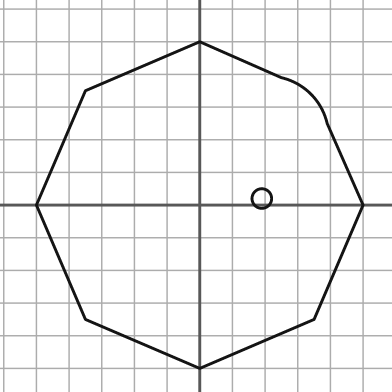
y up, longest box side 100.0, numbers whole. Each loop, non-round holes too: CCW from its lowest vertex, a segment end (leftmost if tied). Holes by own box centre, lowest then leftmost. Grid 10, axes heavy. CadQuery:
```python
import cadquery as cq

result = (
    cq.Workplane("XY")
    .moveTo(0.0, -50.0)
    .lineTo(35.0, -35.0)
    .lineTo(50.0, 0.0)
    .lineTo(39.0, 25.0)
    .threePointArc((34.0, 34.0), (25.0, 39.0))
    .lineTo(0.0, 50.0)
    .lineTo(-35.0, 35.0)
    .lineTo(-50.0, 0.0)
    .lineTo(-35.0, -35.0)
    .close()
    .moveTo(19.0, 2.0)
    .circle(3.0)
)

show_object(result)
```